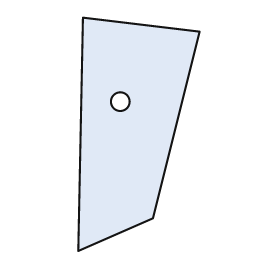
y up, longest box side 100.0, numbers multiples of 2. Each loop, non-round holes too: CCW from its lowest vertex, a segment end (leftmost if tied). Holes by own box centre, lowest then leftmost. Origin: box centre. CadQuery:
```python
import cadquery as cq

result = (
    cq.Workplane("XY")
    .moveTo(-26.0, -50.0)
    .lineTo(6.0, -36.0)
    .lineTo(26.0, 44.0)
    .lineTo(-24.0, 50.0)
    .close()
    .moveTo(-8.0, 14.0)
    .circle(4.0)
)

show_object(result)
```